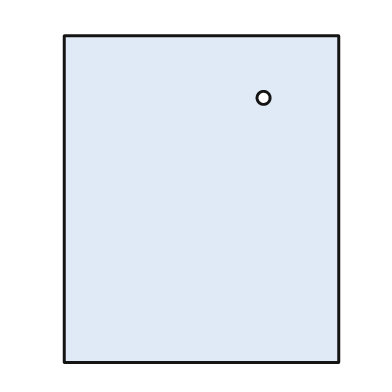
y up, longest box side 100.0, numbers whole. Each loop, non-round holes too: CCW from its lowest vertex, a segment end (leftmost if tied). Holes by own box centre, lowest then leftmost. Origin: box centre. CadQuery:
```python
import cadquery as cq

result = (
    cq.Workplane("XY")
    .moveTo(-42.0, -50.0)
    .lineTo(42.0, -50.0)
    .lineTo(42.0, 50.0)
    .lineTo(-42.0, 50.0)
    .close()
    .moveTo(19.0, 31.0)
    .circle(2.0)
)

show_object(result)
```